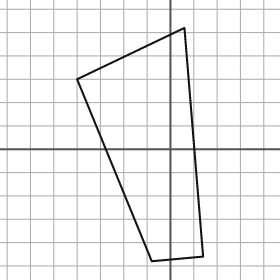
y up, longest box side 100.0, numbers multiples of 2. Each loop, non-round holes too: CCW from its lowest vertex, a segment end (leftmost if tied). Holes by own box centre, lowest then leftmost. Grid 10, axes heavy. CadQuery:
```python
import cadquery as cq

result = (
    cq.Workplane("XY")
    .moveTo(-8.0, -48.0)
    .lineTo(14.0, -46.0)
    .lineTo(6.0, 52.0)
    .lineTo(-40.0, 30.0)
    .close()
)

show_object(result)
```